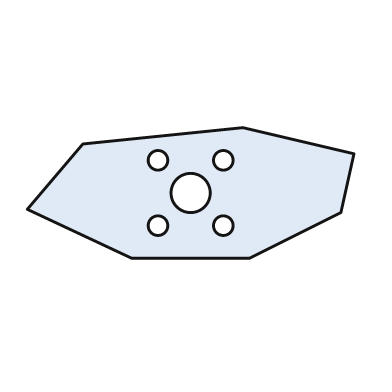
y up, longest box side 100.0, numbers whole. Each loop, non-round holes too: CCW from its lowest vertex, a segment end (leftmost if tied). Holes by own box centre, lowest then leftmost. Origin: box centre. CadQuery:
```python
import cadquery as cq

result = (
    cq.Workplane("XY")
    .moveTo(-18.0, -20.0)
    .lineTo(18.0, -20.0)
    .lineTo(46.0, -6.0)
    .lineTo(50.0, 12.0)
    .lineTo(16.0, 20.0)
    .lineTo(-33.0, 15.0)
    .lineTo(-50.0, -5.0)
    .close()
    .moveTo(-10.0, -10.0)
    .circle(3.0)
    .moveTo(10.0, -10.0)
    .circle(3.0)
    .moveTo(0.0, 0.0)
    .circle(6.0)
    .moveTo(-10.0, 10.0)
    .circle(3.0)
    .moveTo(10.0, 10.0)
    .circle(3.0)
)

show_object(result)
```